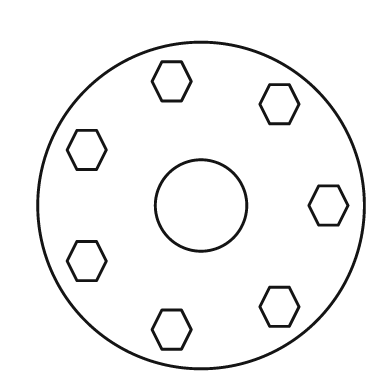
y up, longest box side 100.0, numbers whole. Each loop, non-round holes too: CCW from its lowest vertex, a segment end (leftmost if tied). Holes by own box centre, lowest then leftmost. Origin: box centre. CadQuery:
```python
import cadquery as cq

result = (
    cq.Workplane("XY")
    .moveTo(0.0, 0.0)
    .circle(50.0)
    .moveTo(-12.0, -44.0)
    .lineTo(-6.0, -44.0)
    .lineTo(-3.0, -38.0)
    .lineTo(-6.0, -32.0)
    .lineTo(-12.0, -32.0)
    .lineTo(-15.0, -38.0)
    .close()
    .moveTo(21.0, -37.0)
    .lineTo(27.0, -37.0)
    .lineTo(30.0, -31.0)
    .lineTo(27.0, -25.0)
    .lineTo(21.0, -25.0)
    .lineTo(18.0, -31.0)
    .close()
    .moveTo(-38.0, -23.0)
    .lineTo(-32.0, -23.0)
    .lineTo(-29.0, -17.0)
    .lineTo(-32.0, -11.0)
    .lineTo(-38.0, -11.0)
    .lineTo(-41.0, -17.0)
    .close()
    .moveTo(0.0, 0.0)
    .circle(14.0)
    .moveTo(36.0, -6.0)
    .lineTo(42.0, -6.0)
    .lineTo(45.0, 0.0)
    .lineTo(42.0, 6.0)
    .lineTo(36.0, 6.0)
    .lineTo(33.0, 0.0)
    .close()
    .moveTo(-38.0, 11.0)
    .lineTo(-32.0, 11.0)
    .lineTo(-29.0, 17.0)
    .lineTo(-32.0, 23.0)
    .lineTo(-38.0, 23.0)
    .lineTo(-41.0, 17.0)
    .close()
    .moveTo(21.0, 25.0)
    .lineTo(27.0, 25.0)
    .lineTo(30.0, 31.0)
    .lineTo(27.0, 37.0)
    .lineTo(21.0, 37.0)
    .lineTo(18.0, 31.0)
    .close()
    .moveTo(-12.0, 32.0)
    .lineTo(-6.0, 32.0)
    .lineTo(-3.0, 38.0)
    .lineTo(-6.0, 44.0)
    .lineTo(-12.0, 44.0)
    .lineTo(-15.0, 38.0)
    .close()
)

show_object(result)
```